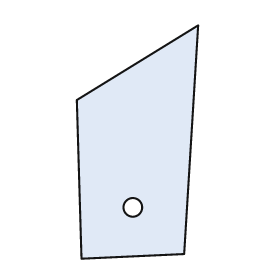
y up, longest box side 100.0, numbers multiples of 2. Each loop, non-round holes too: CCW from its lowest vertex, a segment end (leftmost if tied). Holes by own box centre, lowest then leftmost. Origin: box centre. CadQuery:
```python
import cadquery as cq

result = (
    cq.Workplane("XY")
    .moveTo(-24.0, -50.0)
    .lineTo(20.0, -48.0)
    .lineTo(26.0, 50.0)
    .lineTo(-26.0, 18.0)
    .close()
    .moveTo(-2.0, -28.0)
    .circle(4.0)
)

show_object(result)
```